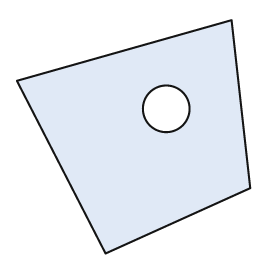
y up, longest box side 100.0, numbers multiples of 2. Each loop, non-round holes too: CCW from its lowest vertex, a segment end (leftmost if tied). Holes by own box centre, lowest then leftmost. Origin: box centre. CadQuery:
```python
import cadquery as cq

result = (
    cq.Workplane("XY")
    .moveTo(-12.0, -50.0)
    .lineTo(50.0, -22.0)
    .lineTo(42.0, 50.0)
    .lineTo(-50.0, 24.0)
    .close()
    .moveTo(14.0, 12.0)
    .circle(10.0)
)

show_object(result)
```